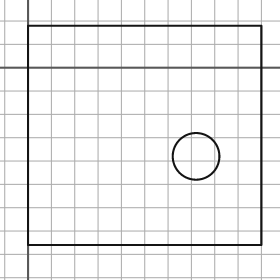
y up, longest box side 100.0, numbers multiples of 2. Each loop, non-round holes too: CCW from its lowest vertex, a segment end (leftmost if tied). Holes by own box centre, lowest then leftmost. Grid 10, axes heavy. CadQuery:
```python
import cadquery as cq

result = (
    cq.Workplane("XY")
    .moveTo(0.0, -76.0)
    .lineTo(100.0, -76.0)
    .lineTo(100.0, 18.0)
    .lineTo(0.0, 18.0)
    .close()
    .moveTo(72.0, -38.0)
    .circle(10.0)
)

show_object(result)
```